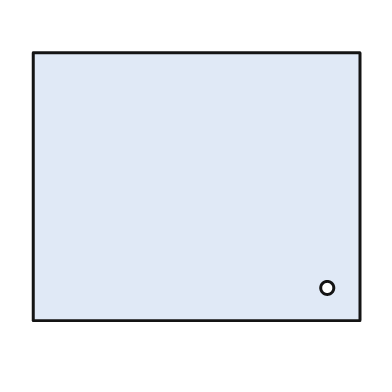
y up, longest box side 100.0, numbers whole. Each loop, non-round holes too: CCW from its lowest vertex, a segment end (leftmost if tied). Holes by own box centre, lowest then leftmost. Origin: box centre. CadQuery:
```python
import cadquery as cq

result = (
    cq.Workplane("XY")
    .moveTo(-50.0, -41.0)
    .lineTo(50.0, -41.0)
    .lineTo(50.0, 41.0)
    .lineTo(-50.0, 41.0)
    .close()
    .moveTo(40.0, -31.0)
    .circle(2.0)
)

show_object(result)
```